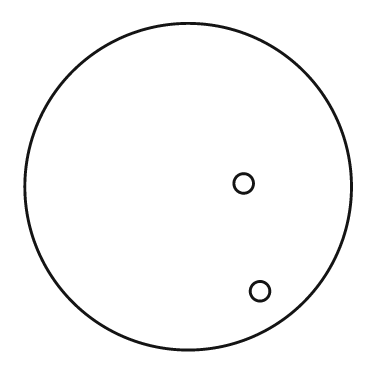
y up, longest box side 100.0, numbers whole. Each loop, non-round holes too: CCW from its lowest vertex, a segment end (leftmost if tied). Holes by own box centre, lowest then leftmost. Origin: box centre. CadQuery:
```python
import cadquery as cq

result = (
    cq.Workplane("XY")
    .moveTo(0.0, 0.0)
    .circle(50.0)
    .moveTo(22.0, -32.0)
    .circle(3.0)
    .moveTo(17.0, 1.0)
    .circle(3.0)
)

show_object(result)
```